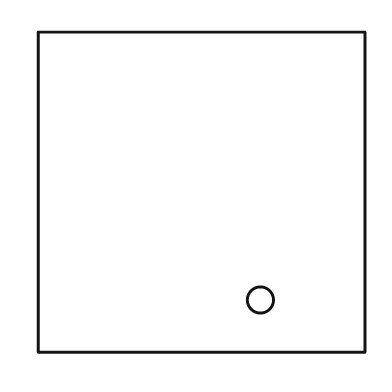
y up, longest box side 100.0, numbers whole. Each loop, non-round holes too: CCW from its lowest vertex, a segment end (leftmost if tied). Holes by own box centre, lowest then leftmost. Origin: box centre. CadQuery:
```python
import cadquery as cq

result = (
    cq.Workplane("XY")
    .moveTo(-50.0, -49.0)
    .lineTo(50.0, -49.0)
    .lineTo(50.0, 49.0)
    .lineTo(-50.0, 49.0)
    .close()
    .moveTo(18.0, -33.0)
    .circle(4.0)
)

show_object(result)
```